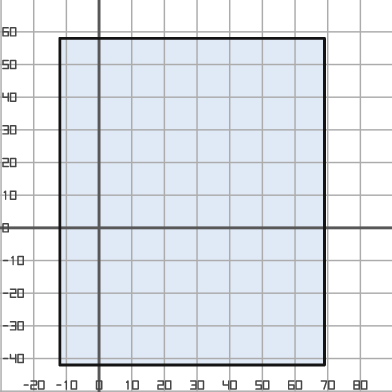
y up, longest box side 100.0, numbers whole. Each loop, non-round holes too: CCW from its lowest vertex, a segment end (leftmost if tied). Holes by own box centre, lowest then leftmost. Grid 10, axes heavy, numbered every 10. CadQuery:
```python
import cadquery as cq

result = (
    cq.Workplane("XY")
    .moveTo(-12.0, -42.0)
    .lineTo(69.0, -42.0)
    .lineTo(69.0, 58.0)
    .lineTo(-12.0, 58.0)
    .close()
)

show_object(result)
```